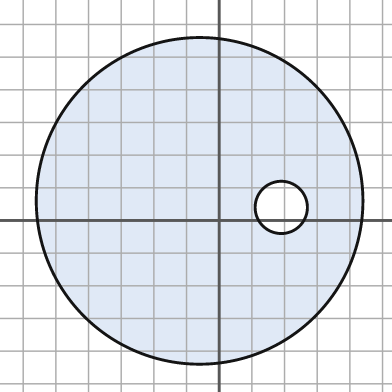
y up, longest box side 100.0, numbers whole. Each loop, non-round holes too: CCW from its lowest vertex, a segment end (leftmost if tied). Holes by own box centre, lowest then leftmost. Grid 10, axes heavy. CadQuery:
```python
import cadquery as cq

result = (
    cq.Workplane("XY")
    .moveTo(-6.0, 6.0)
    .circle(50.0)
    .moveTo(19.0, 4.0)
    .circle(8.0)
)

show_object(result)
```